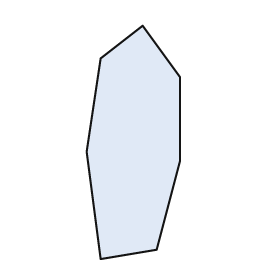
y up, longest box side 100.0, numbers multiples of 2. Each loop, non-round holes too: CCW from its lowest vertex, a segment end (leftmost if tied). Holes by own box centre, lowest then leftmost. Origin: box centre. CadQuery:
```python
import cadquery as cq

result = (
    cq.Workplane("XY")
    .moveTo(-14.0, -50.0)
    .lineTo(10.0, -46.0)
    .lineTo(20.0, -8.0)
    .lineTo(20.0, 28.0)
    .lineTo(4.0, 50.0)
    .lineTo(-14.0, 36.0)
    .lineTo(-20.0, -4.0)
    .close()
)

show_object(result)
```